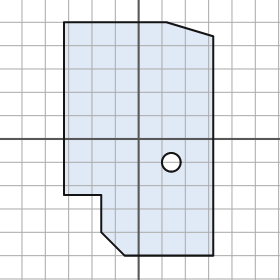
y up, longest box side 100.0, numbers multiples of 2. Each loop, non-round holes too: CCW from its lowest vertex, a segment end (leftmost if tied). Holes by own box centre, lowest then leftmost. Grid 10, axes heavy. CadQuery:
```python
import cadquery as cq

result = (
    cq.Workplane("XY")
    .moveTo(-6.0, -50.0)
    .lineTo(32.0, -50.0)
    .lineTo(32.0, 44.0)
    .lineTo(12.0, 50.0)
    .lineTo(-32.0, 50.0)
    .lineTo(-32.0, -24.0)
    .lineTo(-16.0, -24.0)
    .lineTo(-16.0, -40.0)
    .close()
    .moveTo(14.0, -10.0)
    .circle(4.0)
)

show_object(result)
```